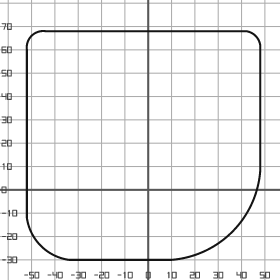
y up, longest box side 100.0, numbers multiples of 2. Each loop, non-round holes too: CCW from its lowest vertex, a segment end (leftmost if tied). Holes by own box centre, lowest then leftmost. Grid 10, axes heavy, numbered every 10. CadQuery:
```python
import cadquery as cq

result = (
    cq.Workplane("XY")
    .moveTo(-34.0, -30.0)
    .lineTo(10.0, -30.0)
    .threePointArc((36.0, -18.0), (48.0, 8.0))
    .lineTo(48.0, 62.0)
    .threePointArc((46.0, 66.0), (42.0, 68.0))
    .lineTo(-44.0, 68.0)
    .threePointArc((-50.0, 66.0), (-52.0, 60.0))
    .lineTo(-52.0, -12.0)
    .threePointArc((-46.0, -24.0), (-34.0, -30.0))
    .close()
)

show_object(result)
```